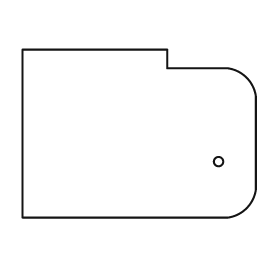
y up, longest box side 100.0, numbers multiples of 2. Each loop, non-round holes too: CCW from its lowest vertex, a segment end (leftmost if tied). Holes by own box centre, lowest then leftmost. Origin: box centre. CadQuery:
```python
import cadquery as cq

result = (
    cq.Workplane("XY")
    .moveTo(-50.0, -36.0)
    .lineTo(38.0, -36.0)
    .threePointArc((46.0, -32.0), (50.0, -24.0))
    .lineTo(50.0, 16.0)
    .threePointArc((46.0, 24.0), (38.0, 28.0))
    .lineTo(12.0, 28.0)
    .lineTo(12.0, 36.0)
    .lineTo(-50.0, 36.0)
    .close()
    .moveTo(34.0, -12.0)
    .circle(2.0)
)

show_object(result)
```